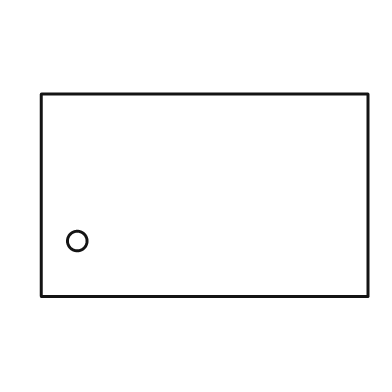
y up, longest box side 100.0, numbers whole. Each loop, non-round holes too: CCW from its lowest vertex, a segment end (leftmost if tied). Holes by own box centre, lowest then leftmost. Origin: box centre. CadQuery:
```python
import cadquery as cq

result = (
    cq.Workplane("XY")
    .moveTo(-50.0, -31.0)
    .lineTo(50.0, -31.0)
    .lineTo(50.0, 31.0)
    .lineTo(-50.0, 31.0)
    .close()
    .moveTo(-39.0, -14.0)
    .circle(3.0)
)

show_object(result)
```